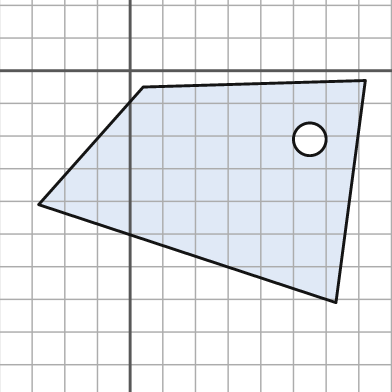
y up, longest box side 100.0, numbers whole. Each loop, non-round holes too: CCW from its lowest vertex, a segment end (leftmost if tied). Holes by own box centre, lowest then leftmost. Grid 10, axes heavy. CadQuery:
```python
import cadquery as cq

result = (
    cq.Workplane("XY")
    .moveTo(63.0, -71.0)
    .lineTo(72.0, -3.0)
    .lineTo(4.0, -5.0)
    .lineTo(-28.0, -41.0)
    .close()
    .moveTo(55.0, -21.0)
    .circle(5.0)
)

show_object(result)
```